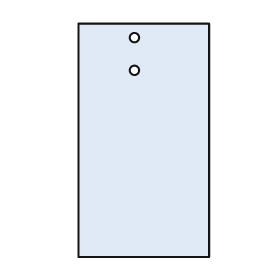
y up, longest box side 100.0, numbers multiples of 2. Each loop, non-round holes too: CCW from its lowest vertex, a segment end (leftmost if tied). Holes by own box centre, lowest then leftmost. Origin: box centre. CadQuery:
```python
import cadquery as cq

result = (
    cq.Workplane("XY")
    .moveTo(-28.0, -50.0)
    .lineTo(28.0, -50.0)
    .lineTo(28.0, 50.0)
    .lineTo(-28.0, 50.0)
    .close()
    .moveTo(-4.0, 30.0)
    .circle(2.0)
    .moveTo(-4.0, 44.0)
    .circle(2.0)
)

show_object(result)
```